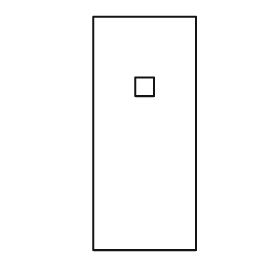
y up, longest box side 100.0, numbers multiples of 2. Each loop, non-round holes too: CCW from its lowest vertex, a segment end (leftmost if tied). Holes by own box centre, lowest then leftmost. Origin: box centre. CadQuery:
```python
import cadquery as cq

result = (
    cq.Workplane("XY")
    .moveTo(-22.0, -50.0)
    .lineTo(22.0, -50.0)
    .lineTo(22.0, 50.0)
    .lineTo(-22.0, 50.0)
    .close()
    .moveTo(-4.0, 16.0)
    .lineTo(4.0, 16.0)
    .lineTo(4.0, 24.0)
    .lineTo(-4.0, 24.0)
    .close()
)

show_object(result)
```